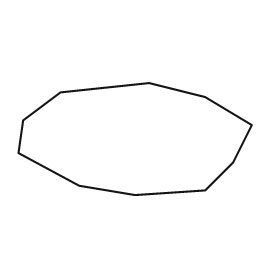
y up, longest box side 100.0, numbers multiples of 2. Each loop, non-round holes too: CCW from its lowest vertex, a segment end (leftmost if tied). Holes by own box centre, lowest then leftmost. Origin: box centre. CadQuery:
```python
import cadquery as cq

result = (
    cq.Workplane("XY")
    .moveTo(0.0, -24.0)
    .lineTo(30.0, -22.0)
    .lineTo(42.0, -10.0)
    .lineTo(50.0, 6.0)
    .lineTo(30.0, 18.0)
    .lineTo(6.0, 24.0)
    .lineTo(-32.0, 20.0)
    .lineTo(-48.0, 8.0)
    .lineTo(-50.0, -6.0)
    .lineTo(-24.0, -20.0)
    .close()
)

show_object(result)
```